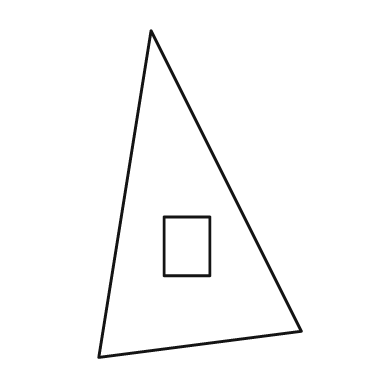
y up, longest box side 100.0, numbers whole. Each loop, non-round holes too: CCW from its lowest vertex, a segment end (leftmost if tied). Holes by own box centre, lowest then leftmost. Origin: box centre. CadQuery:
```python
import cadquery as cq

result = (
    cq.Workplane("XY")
    .moveTo(-31.0, -50.0)
    .lineTo(31.0, -42.0)
    .lineTo(-15.0, 50.0)
    .close()
    .moveTo(-11.0, -25.0)
    .lineTo(3.0, -25.0)
    .lineTo(3.0, -7.0)
    .lineTo(-11.0, -7.0)
    .close()
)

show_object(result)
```